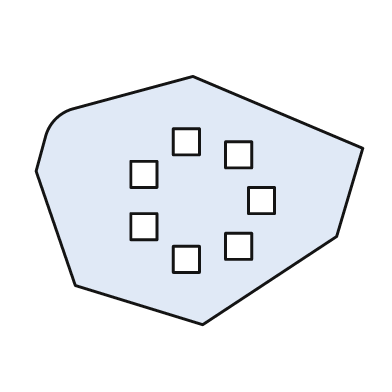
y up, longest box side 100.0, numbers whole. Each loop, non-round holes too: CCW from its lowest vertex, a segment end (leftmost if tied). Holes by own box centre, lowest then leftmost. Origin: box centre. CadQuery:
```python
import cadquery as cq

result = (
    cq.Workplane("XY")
    .moveTo(1.0, -38.0)
    .lineTo(42.0, -11.0)
    .lineTo(50.0, 16.0)
    .lineTo(-2.0, 38.0)
    .lineTo(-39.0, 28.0)
    .threePointArc((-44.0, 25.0), (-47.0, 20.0))
    .lineTo(-50.0, 9.0)
    .lineTo(-38.0, -26.0)
    .close()
    .moveTo(-8.0, -22.0)
    .lineTo(0.0, -22.0)
    .lineTo(0.0, -14.0)
    .lineTo(-8.0, -14.0)
    .close()
    .moveTo(8.0, -18.0)
    .lineTo(16.0, -18.0)
    .lineTo(16.0, -10.0)
    .lineTo(8.0, -10.0)
    .close()
    .moveTo(-21.0, -12.0)
    .lineTo(-13.0, -12.0)
    .lineTo(-13.0, -4.0)
    .lineTo(-21.0, -4.0)
    .close()
    .moveTo(15.0, -4.0)
    .lineTo(23.0, -4.0)
    .lineTo(23.0, 4.0)
    .lineTo(15.0, 4.0)
    .close()
    .moveTo(-21.0, 4.0)
    .lineTo(-13.0, 4.0)
    .lineTo(-13.0, 12.0)
    .lineTo(-21.0, 12.0)
    .close()
    .moveTo(8.0, 10.0)
    .lineTo(16.0, 10.0)
    .lineTo(16.0, 18.0)
    .lineTo(8.0, 18.0)
    .close()
    .moveTo(-8.0, 14.0)
    .lineTo(0.0, 14.0)
    .lineTo(0.0, 22.0)
    .lineTo(-8.0, 22.0)
    .close()
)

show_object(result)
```